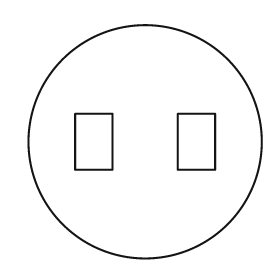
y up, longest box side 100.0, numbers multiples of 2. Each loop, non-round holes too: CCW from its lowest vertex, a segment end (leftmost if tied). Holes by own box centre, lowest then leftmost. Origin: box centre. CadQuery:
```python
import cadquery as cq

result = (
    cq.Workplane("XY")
    .moveTo(0.0, 0.0)
    .circle(50.0)
    .moveTo(-30.0, -12.0)
    .lineTo(-14.0, -12.0)
    .lineTo(-14.0, 12.0)
    .lineTo(-30.0, 12.0)
    .close()
    .moveTo(14.0, -12.0)
    .lineTo(30.0, -12.0)
    .lineTo(30.0, 12.0)
    .lineTo(14.0, 12.0)
    .close()
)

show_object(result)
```